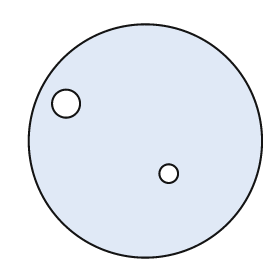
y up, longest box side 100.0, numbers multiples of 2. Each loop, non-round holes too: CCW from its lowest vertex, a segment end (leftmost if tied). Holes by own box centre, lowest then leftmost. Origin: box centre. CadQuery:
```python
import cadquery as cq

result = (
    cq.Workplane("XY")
    .moveTo(0.0, 0.0)
    .circle(50.0)
    .moveTo(10.0, -14.0)
    .circle(4.0)
    .moveTo(-34.0, 16.0)
    .circle(6.0)
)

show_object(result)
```